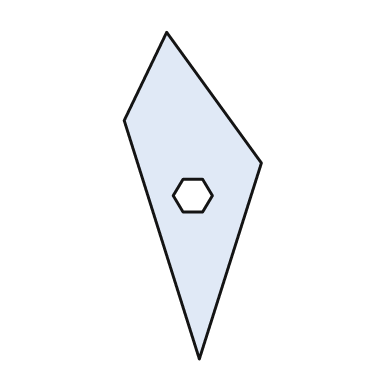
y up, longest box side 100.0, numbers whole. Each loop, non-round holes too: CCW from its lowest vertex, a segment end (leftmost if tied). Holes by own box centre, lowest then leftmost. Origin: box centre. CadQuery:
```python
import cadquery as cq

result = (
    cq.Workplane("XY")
    .moveTo(2.0, -50.0)
    .lineTo(21.0, 10.0)
    .lineTo(-8.0, 50.0)
    .lineTo(-21.0, 23.0)
    .close()
    .moveTo(-3.0, -5.0)
    .lineTo(3.0, -5.0)
    .lineTo(6.0, 0.0)
    .lineTo(3.0, 5.0)
    .lineTo(-3.0, 5.0)
    .lineTo(-6.0, 0.0)
    .close()
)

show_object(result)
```